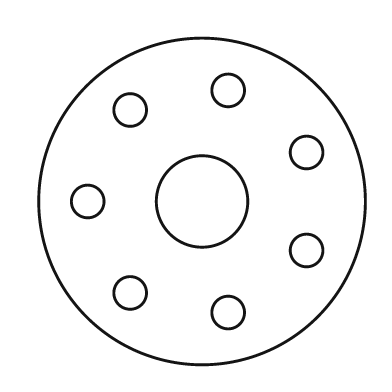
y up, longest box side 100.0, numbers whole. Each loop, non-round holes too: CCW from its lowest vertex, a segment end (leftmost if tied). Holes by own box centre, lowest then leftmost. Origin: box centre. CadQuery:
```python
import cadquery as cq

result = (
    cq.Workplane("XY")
    .moveTo(0.0, 0.0)
    .circle(50.0)
    .moveTo(8.0, -34.0)
    .circle(5.0)
    .moveTo(-22.0, -28.0)
    .circle(5.0)
    .moveTo(32.0, -15.0)
    .circle(5.0)
    .moveTo(-35.0, 0.0)
    .circle(5.0)
    .moveTo(0.0, 0.0)
    .circle(14.0)
    .moveTo(32.0, 15.0)
    .circle(5.0)
    .moveTo(-22.0, 28.0)
    .circle(5.0)
    .moveTo(8.0, 34.0)
    .circle(5.0)
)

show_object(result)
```